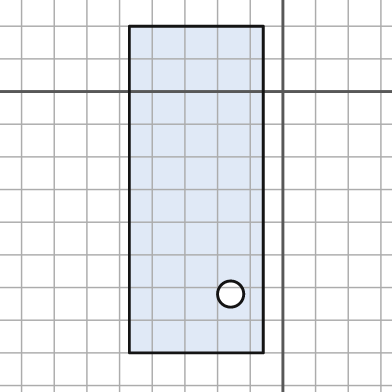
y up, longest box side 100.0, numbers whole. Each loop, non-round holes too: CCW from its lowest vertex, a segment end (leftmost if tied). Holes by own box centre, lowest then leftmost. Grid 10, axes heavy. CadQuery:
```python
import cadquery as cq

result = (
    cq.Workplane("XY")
    .moveTo(-47.0, -80.0)
    .lineTo(-6.0, -80.0)
    .lineTo(-6.0, 20.0)
    .lineTo(-47.0, 20.0)
    .close()
    .moveTo(-16.0, -62.0)
    .circle(4.0)
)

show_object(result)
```